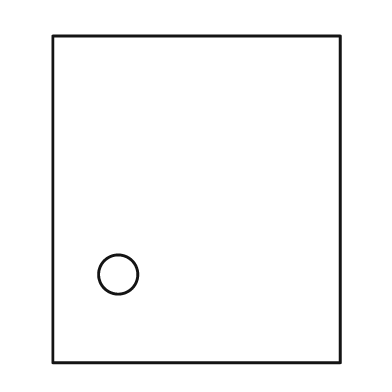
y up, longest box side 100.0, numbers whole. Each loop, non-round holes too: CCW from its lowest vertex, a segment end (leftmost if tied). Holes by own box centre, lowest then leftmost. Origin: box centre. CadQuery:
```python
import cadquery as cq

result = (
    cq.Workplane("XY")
    .moveTo(-44.0, -50.0)
    .lineTo(44.0, -50.0)
    .lineTo(44.0, 50.0)
    .lineTo(-44.0, 50.0)
    .close()
    .moveTo(-24.0, -23.0)
    .circle(6.0)
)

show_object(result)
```